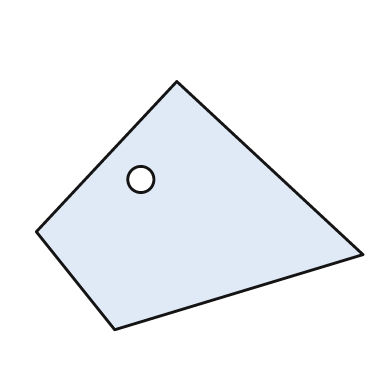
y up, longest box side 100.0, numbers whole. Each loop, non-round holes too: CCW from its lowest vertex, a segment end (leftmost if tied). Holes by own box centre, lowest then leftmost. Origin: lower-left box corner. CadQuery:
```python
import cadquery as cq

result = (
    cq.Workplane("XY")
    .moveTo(24.0, 0.0)
    .lineTo(100.0, 23.0)
    .lineTo(43.0, 76.0)
    .lineTo(0.0, 30.0)
    .close()
    .moveTo(32.0, 46.0)
    .circle(4.0)
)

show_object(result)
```